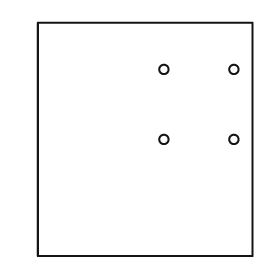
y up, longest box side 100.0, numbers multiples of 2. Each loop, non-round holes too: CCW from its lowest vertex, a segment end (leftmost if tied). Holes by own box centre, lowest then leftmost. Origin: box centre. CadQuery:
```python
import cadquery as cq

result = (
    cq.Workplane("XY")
    .moveTo(-46.0, -50.0)
    .lineTo(46.0, -50.0)
    .lineTo(46.0, 50.0)
    .lineTo(-46.0, 50.0)
    .close()
    .moveTo(8.0, 0.0)
    .circle(2.0)
    .moveTo(38.0, 0.0)
    .circle(2.0)
    .moveTo(8.0, 30.0)
    .circle(2.0)
    .moveTo(38.0, 30.0)
    .circle(2.0)
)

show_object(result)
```